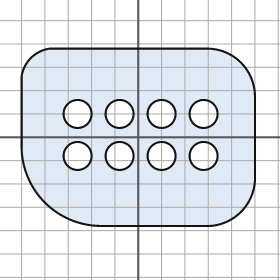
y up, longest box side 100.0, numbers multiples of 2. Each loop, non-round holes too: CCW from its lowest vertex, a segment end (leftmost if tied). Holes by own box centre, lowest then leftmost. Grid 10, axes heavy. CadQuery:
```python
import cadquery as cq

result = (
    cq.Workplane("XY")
    .moveTo(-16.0, -38.0)
    .lineTo(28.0, -38.0)
    .threePointArc((44.0, -32.0), (50.0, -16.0))
    .lineTo(50.0, 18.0)
    .threePointArc((44.0, 32.0), (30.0, 38.0))
    .lineTo(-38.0, 38.0)
    .threePointArc((-46.0, 34.0), (-50.0, 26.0))
    .lineTo(-50.0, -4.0)
    .threePointArc((-40.0, -28.0), (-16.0, -38.0))
    .close()
    .moveTo(-26.0, -8.0)
    .circle(6.0)
    .moveTo(-8.0, -8.0)
    .circle(6.0)
    .moveTo(10.0, -8.0)
    .circle(6.0)
    .moveTo(28.0, -8.0)
    .circle(6.0)
    .moveTo(-26.0, 10.0)
    .circle(6.0)
    .moveTo(-8.0, 10.0)
    .circle(6.0)
    .moveTo(10.0, 10.0)
    .circle(6.0)
    .moveTo(28.0, 10.0)
    .circle(6.0)
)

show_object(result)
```